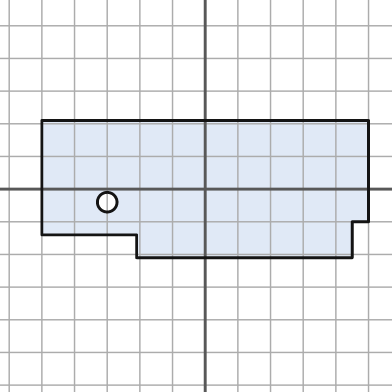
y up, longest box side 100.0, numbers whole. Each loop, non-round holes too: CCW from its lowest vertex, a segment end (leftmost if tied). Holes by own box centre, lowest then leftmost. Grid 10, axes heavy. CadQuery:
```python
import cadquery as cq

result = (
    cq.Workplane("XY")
    .moveTo(-21.0, -21.0)
    .lineTo(45.0, -21.0)
    .lineTo(45.0, -10.0)
    .lineTo(50.0, -10.0)
    .lineTo(50.0, 21.0)
    .lineTo(-50.0, 21.0)
    .lineTo(-50.0, -14.0)
    .lineTo(-21.0, -14.0)
    .close()
    .moveTo(-30.0, -4.0)
    .circle(3.0)
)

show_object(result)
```